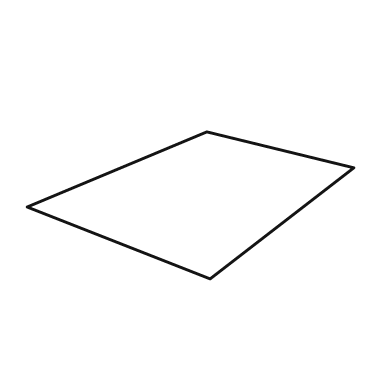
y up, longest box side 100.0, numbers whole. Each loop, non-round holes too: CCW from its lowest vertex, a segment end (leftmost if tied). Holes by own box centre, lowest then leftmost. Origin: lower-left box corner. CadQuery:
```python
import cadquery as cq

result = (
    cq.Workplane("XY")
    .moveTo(56.0, 0.0)
    .lineTo(100.0, 34.0)
    .lineTo(55.0, 45.0)
    .lineTo(0.0, 22.0)
    .close()
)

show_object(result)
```